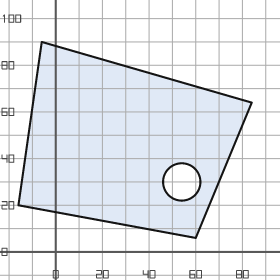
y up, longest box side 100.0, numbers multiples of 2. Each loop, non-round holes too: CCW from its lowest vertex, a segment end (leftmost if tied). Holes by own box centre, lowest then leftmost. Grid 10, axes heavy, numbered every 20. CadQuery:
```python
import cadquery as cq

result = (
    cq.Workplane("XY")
    .moveTo(60.0, 6.0)
    .lineTo(84.0, 64.0)
    .lineTo(-6.0, 90.0)
    .lineTo(-16.0, 20.0)
    .close()
    .moveTo(54.0, 30.0)
    .circle(8.0)
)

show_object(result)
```